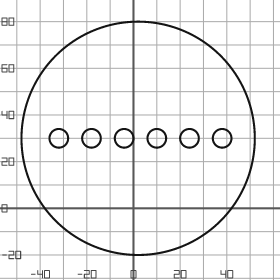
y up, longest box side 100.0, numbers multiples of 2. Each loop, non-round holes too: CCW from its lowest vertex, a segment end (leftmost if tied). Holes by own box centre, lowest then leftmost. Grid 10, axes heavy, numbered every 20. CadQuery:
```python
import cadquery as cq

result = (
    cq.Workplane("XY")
    .moveTo(2.0, 30.0)
    .circle(50.0)
    .moveTo(-32.0, 30.0)
    .circle(4.0)
    .moveTo(-18.0, 30.0)
    .circle(4.0)
    .moveTo(-4.0, 30.0)
    .circle(4.0)
    .moveTo(10.0, 30.0)
    .circle(4.0)
    .moveTo(24.0, 30.0)
    .circle(4.0)
    .moveTo(38.0, 30.0)
    .circle(4.0)
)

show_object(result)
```